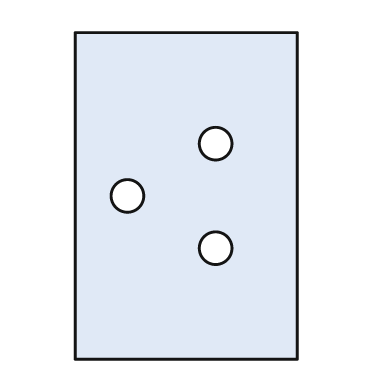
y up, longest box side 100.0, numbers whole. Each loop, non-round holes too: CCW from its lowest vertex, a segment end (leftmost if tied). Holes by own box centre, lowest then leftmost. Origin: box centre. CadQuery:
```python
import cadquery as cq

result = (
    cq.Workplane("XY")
    .moveTo(-34.0, -50.0)
    .lineTo(34.0, -50.0)
    .lineTo(34.0, 50.0)
    .lineTo(-34.0, 50.0)
    .close()
    .moveTo(9.0, -16.0)
    .circle(5.0)
    .moveTo(-18.0, 0.0)
    .circle(5.0)
    .moveTo(9.0, 16.0)
    .circle(5.0)
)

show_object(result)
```